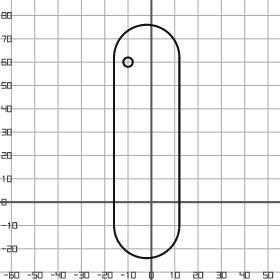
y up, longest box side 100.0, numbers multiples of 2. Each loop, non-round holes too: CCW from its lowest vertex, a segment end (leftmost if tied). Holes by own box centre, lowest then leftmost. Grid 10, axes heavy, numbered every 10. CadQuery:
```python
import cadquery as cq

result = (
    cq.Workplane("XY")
    .moveTo(-16.0, -10.0)
    .threePointArc((-2.0, -24.0), (12.0, -10.0))
    .lineTo(12.0, 62.0)
    .threePointArc((-2.0, 76.0), (-16.0, 62.0))
    .close()
    .moveTo(-10.0, 60.0)
    .circle(2.0)
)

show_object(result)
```